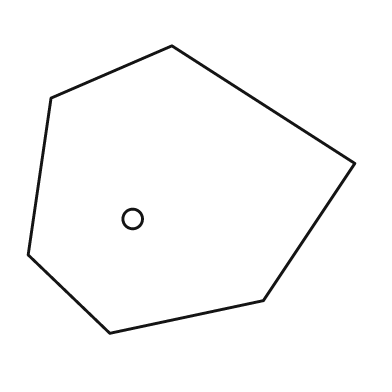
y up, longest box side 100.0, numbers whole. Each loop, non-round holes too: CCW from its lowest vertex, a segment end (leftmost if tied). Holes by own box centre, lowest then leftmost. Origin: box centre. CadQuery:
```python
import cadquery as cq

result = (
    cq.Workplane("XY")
    .moveTo(-25.0, -44.0)
    .lineTo(22.0, -34.0)
    .lineTo(50.0, 8.0)
    .lineTo(-6.0, 44.0)
    .lineTo(-43.0, 28.0)
    .lineTo(-50.0, -20.0)
    .close()
    .moveTo(-18.0, -9.0)
    .circle(3.0)
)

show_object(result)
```